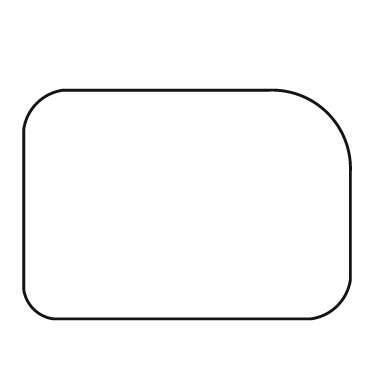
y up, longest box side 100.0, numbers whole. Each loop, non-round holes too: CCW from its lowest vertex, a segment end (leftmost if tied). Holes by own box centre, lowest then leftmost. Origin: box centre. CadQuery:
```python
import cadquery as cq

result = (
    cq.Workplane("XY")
    .moveTo(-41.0, -35.0)
    .lineTo(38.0, -35.0)
    .threePointArc((46.0, -31.0), (50.0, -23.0))
    .lineTo(50.0, 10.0)
    .threePointArc((43.0, 28.0), (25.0, 35.0))
    .lineTo(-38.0, 35.0)
    .threePointArc((-46.0, 31.0), (-50.0, 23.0))
    .lineTo(-50.0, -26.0)
    .threePointArc((-47.0, -32.0), (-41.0, -35.0))
    .close()
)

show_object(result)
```